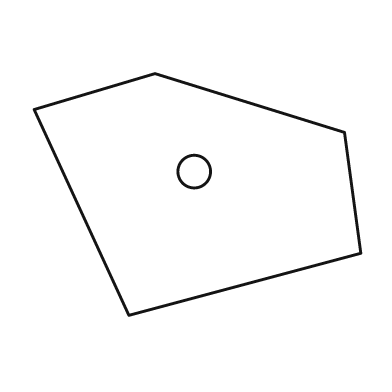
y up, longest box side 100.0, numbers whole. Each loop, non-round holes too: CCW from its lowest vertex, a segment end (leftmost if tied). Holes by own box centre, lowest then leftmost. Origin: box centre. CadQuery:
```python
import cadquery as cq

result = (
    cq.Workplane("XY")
    .moveTo(-21.0, -37.0)
    .lineTo(50.0, -18.0)
    .lineTo(45.0, 19.0)
    .lineTo(-13.0, 37.0)
    .lineTo(-50.0, 26.0)
    .close()
    .moveTo(-1.0, 7.0)
    .circle(5.0)
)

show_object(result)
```